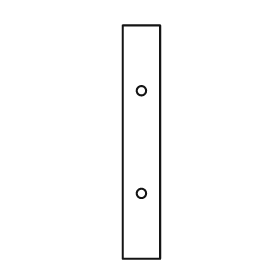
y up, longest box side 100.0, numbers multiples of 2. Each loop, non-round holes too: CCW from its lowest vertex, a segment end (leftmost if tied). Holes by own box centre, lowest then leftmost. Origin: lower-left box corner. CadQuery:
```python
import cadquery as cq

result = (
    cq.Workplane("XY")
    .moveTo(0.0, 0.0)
    .lineTo(16.0, 0.0)
    .lineTo(16.0, 100.0)
    .lineTo(0.0, 100.0)
    .close()
    .moveTo(8.0, 28.0)
    .circle(2.0)
    .moveTo(8.0, 72.0)
    .circle(2.0)
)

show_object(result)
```